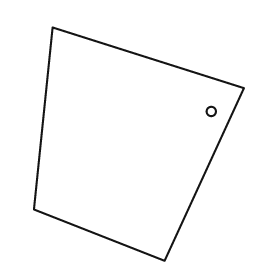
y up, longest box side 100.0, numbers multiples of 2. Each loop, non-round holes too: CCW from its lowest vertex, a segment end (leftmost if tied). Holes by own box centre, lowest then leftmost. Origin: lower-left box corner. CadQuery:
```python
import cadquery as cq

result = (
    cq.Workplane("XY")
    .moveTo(56.0, 0.0)
    .lineTo(90.0, 74.0)
    .lineTo(8.0, 100.0)
    .lineTo(0.0, 22.0)
    .close()
    .moveTo(76.0, 64.0)
    .circle(2.0)
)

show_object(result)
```